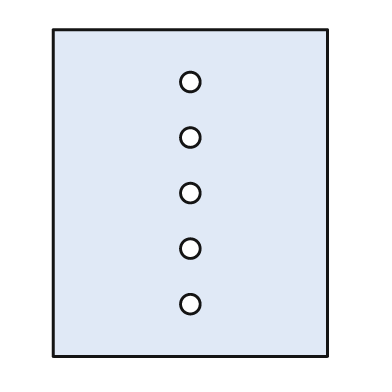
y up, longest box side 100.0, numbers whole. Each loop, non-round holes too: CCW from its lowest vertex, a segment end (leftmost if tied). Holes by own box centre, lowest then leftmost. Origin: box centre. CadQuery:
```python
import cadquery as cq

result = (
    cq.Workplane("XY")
    .moveTo(-42.0, -50.0)
    .lineTo(42.0, -50.0)
    .lineTo(42.0, 50.0)
    .lineTo(-42.0, 50.0)
    .close()
    .moveTo(0.0, -34.0)
    .circle(3.0)
    .moveTo(0.0, -17.0)
    .circle(3.0)
    .moveTo(0.0, 0.0)
    .circle(3.0)
    .moveTo(0.0, 17.0)
    .circle(3.0)
    .moveTo(0.0, 34.0)
    .circle(3.0)
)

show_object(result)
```